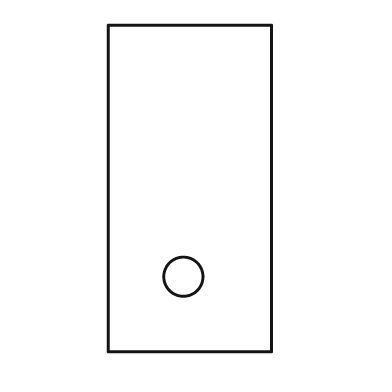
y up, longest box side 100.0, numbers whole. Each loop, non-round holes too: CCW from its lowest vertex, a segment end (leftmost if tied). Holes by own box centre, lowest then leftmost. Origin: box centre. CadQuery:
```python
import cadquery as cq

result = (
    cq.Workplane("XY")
    .moveTo(-25.0, -50.0)
    .lineTo(25.0, -50.0)
    .lineTo(25.0, 50.0)
    .lineTo(-25.0, 50.0)
    .close()
    .moveTo(-2.0, -27.0)
    .circle(6.0)
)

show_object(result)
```